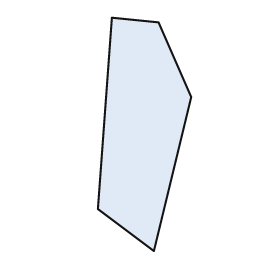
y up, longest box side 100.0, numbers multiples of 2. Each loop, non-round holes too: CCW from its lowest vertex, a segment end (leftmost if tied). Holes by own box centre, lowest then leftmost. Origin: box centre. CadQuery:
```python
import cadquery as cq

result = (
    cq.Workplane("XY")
    .moveTo(4.0, -50.0)
    .lineTo(20.0, 16.0)
    .lineTo(6.0, 48.0)
    .lineTo(-14.0, 50.0)
    .lineTo(-20.0, -32.0)
    .close()
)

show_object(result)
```